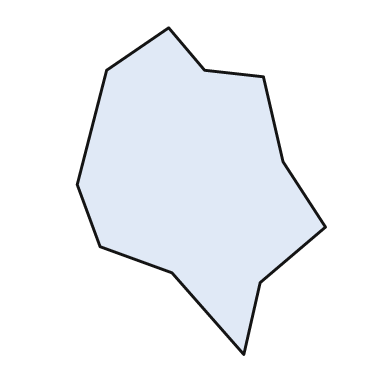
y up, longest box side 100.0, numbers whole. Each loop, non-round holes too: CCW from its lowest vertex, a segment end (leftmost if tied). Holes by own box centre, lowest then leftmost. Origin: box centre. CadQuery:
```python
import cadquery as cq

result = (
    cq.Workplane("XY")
    .moveTo(13.0, -50.0)
    .lineTo(18.0, -28.0)
    .lineTo(38.0, -11.0)
    .lineTo(25.0, 9.0)
    .lineTo(19.0, 35.0)
    .lineTo(1.0, 37.0)
    .lineTo(-10.0, 50.0)
    .lineTo(-29.0, 37.0)
    .lineTo(-38.0, 2.0)
    .lineTo(-31.0, -17.0)
    .lineTo(-9.0, -25.0)
    .close()
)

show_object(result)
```